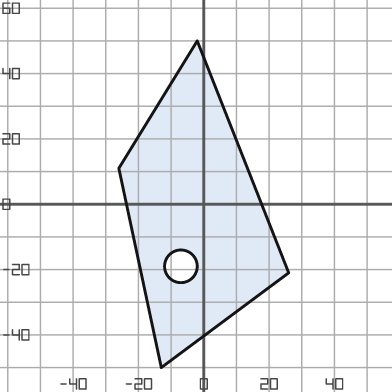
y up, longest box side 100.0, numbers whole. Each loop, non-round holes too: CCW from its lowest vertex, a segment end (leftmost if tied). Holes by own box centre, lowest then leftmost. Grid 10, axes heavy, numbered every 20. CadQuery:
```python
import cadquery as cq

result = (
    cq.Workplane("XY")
    .moveTo(-13.0, -50.0)
    .lineTo(26.0, -21.0)
    .lineTo(-2.0, 50.0)
    .lineTo(-26.0, 11.0)
    .close()
    .moveTo(-7.0, -19.0)
    .circle(5.0)
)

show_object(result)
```